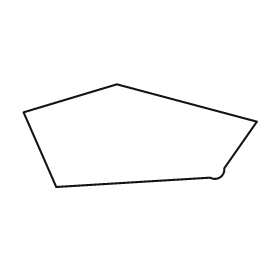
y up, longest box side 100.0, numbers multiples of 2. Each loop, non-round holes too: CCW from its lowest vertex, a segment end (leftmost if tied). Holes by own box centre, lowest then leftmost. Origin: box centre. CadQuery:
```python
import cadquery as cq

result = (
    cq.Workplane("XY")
    .moveTo(-36.0, -22.0)
    .lineTo(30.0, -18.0)
    .threePointArc((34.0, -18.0), (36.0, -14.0))
    .lineTo(50.0, 6.0)
    .lineTo(-10.0, 22.0)
    .lineTo(-50.0, 10.0)
    .close()
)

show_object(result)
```